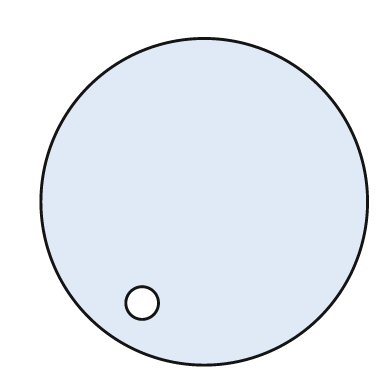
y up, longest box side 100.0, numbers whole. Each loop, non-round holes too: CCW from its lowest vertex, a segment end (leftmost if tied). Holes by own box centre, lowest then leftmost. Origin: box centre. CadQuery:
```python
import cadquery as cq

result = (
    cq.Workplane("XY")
    .moveTo(0.0, 0.0)
    .circle(50.0)
    .moveTo(-19.0, -31.0)
    .circle(5.0)
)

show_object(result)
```